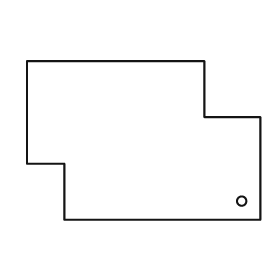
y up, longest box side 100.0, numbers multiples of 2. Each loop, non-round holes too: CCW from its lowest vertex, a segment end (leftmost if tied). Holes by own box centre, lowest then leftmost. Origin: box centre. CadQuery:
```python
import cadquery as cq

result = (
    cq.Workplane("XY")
    .moveTo(-34.0, -34.0)
    .lineTo(50.0, -34.0)
    .lineTo(50.0, 10.0)
    .lineTo(26.0, 10.0)
    .lineTo(26.0, 34.0)
    .lineTo(-50.0, 34.0)
    .lineTo(-50.0, -10.0)
    .lineTo(-34.0, -10.0)
    .close()
    .moveTo(42.0, -26.0)
    .circle(2.0)
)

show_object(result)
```